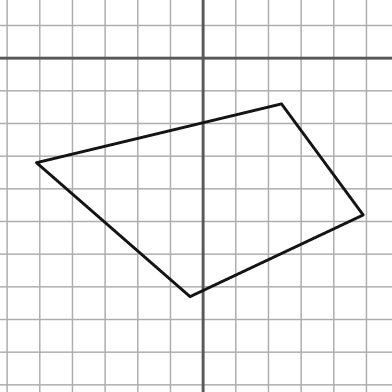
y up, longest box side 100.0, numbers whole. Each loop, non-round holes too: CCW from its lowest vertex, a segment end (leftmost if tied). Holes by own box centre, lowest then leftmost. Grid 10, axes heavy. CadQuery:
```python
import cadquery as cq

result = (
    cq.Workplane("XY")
    .moveTo(-4.0, -73.0)
    .lineTo(49.0, -48.0)
    .lineTo(24.0, -14.0)
    .lineTo(-51.0, -32.0)
    .close()
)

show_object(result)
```